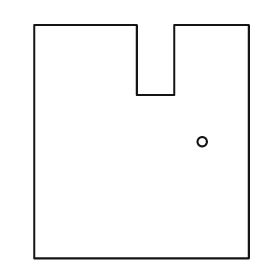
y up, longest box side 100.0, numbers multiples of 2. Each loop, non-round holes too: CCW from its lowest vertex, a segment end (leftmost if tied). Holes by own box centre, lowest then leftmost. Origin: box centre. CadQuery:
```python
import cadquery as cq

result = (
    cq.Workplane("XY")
    .moveTo(-46.0, -50.0)
    .lineTo(46.0, -50.0)
    .lineTo(46.0, 50.0)
    .lineTo(14.0, 50.0)
    .lineTo(14.0, 20.0)
    .lineTo(-2.0, 20.0)
    .lineTo(-2.0, 50.0)
    .lineTo(-46.0, 50.0)
    .close()
    .moveTo(26.0, 0.0)
    .circle(2.0)
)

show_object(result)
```